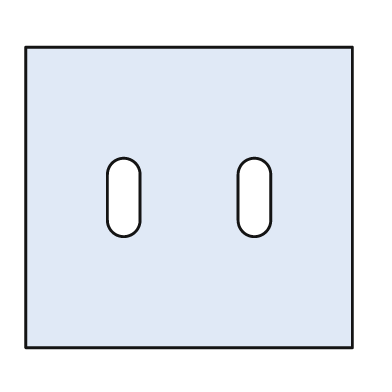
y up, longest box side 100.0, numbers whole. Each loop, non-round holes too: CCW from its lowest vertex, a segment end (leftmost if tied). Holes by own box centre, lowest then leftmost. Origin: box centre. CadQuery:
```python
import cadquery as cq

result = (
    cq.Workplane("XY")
    .moveTo(-50.0, -46.0)
    .lineTo(50.0, -46.0)
    .lineTo(50.0, 46.0)
    .lineTo(-50.0, 46.0)
    .close()
    .moveTo(-25.0, -7.0)
    .threePointArc((-20.0, -12.0), (-15.0, -7.0))
    .lineTo(-15.0, 7.0)
    .threePointArc((-20.0, 12.0), (-25.0, 7.0))
    .close()
    .moveTo(15.0, -7.0)
    .threePointArc((20.0, -12.0), (25.0, -7.0))
    .lineTo(25.0, 7.0)
    .threePointArc((20.0, 12.0), (15.0, 7.0))
    .close()
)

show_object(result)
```